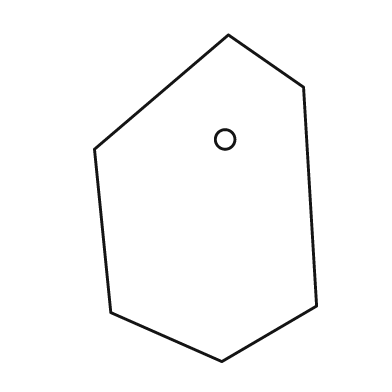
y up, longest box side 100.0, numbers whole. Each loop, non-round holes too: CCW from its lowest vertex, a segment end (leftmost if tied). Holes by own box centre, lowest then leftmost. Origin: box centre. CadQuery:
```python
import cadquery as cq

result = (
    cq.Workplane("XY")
    .moveTo(5.0, -50.0)
    .lineTo(34.0, -33.0)
    .lineTo(30.0, 34.0)
    .lineTo(7.0, 50.0)
    .lineTo(-34.0, 15.0)
    .lineTo(-29.0, -35.0)
    .close()
    .moveTo(6.0, 18.0)
    .circle(3.0)
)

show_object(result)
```